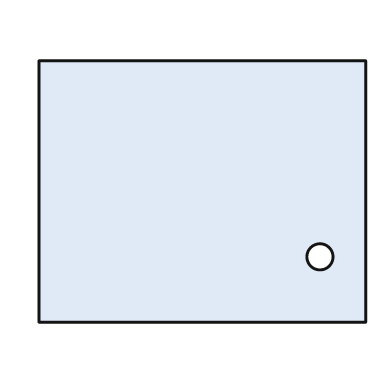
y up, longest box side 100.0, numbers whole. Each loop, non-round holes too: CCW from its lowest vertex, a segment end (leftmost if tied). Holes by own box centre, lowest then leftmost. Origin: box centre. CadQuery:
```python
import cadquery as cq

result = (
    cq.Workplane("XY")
    .moveTo(-50.0, -40.0)
    .lineTo(50.0, -40.0)
    .lineTo(50.0, 40.0)
    .lineTo(-50.0, 40.0)
    .close()
    .moveTo(36.0, -20.0)
    .circle(4.0)
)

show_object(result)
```